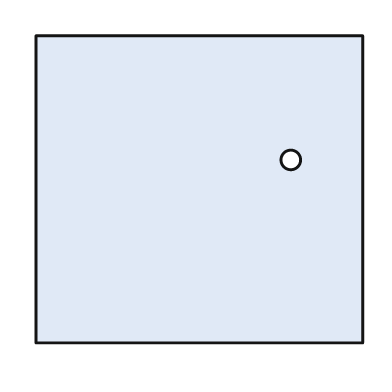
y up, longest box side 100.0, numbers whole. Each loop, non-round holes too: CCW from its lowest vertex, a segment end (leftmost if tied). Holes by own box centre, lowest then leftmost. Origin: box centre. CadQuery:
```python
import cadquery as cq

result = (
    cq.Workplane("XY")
    .moveTo(-50.0, -47.0)
    .lineTo(50.0, -47.0)
    .lineTo(50.0, 47.0)
    .lineTo(-50.0, 47.0)
    .close()
    .moveTo(28.0, 9.0)
    .circle(3.0)
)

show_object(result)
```